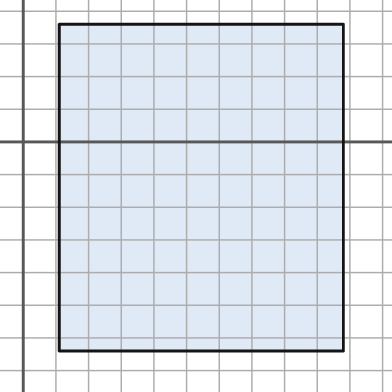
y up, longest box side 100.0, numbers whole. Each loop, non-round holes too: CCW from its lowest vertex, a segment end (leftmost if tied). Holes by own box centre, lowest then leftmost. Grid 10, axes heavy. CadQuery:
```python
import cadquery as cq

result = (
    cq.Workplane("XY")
    .moveTo(11.0, -64.0)
    .lineTo(98.0, -64.0)
    .lineTo(98.0, 36.0)
    .lineTo(11.0, 36.0)
    .close()
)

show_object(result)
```